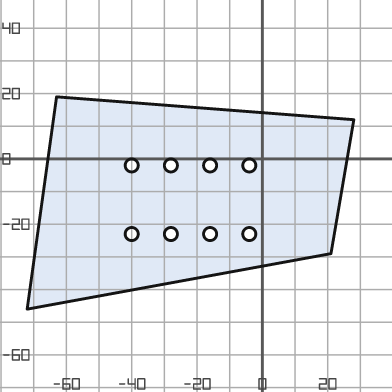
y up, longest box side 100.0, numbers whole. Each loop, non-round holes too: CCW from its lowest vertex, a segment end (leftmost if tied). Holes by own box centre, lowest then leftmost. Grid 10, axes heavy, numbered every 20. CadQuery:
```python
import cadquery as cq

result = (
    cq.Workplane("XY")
    .moveTo(-72.0, -46.0)
    .lineTo(21.0, -29.0)
    .lineTo(28.0, 12.0)
    .lineTo(-63.0, 19.0)
    .close()
    .moveTo(-40.0, -23.0)
    .circle(2.0)
    .moveTo(-28.0, -23.0)
    .circle(2.0)
    .moveTo(-16.0, -23.0)
    .circle(2.0)
    .moveTo(-4.0, -23.0)
    .circle(2.0)
    .moveTo(-40.0, -2.0)
    .circle(2.0)
    .moveTo(-28.0, -2.0)
    .circle(2.0)
    .moveTo(-16.0, -2.0)
    .circle(2.0)
    .moveTo(-4.0, -2.0)
    .circle(2.0)
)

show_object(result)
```